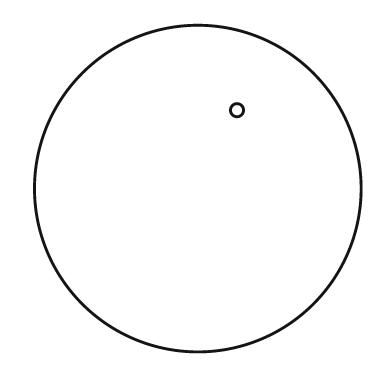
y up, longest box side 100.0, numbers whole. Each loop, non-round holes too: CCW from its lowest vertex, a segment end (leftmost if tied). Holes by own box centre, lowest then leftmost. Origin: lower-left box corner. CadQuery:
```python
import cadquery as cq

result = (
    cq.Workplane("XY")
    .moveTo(50.0, 50.0)
    .circle(50.0)
    .moveTo(62.0, 74.0)
    .circle(2.0)
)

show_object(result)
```